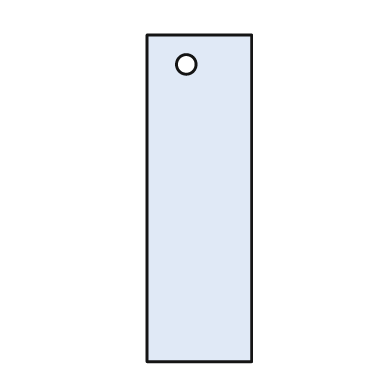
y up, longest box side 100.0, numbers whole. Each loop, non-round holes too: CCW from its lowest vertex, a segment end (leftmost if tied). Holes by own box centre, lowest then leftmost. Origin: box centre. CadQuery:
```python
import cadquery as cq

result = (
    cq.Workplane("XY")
    .moveTo(-16.0, -50.0)
    .lineTo(16.0, -50.0)
    .lineTo(16.0, 50.0)
    .lineTo(-16.0, 50.0)
    .close()
    .moveTo(-4.0, 41.0)
    .circle(3.0)
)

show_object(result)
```